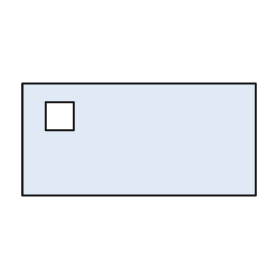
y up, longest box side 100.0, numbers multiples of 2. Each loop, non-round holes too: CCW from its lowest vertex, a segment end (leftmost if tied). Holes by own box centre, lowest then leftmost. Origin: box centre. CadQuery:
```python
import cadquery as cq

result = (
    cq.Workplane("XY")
    .moveTo(-50.0, -24.0)
    .lineTo(50.0, -24.0)
    .lineTo(50.0, 24.0)
    .lineTo(-50.0, 24.0)
    .close()
    .moveTo(-40.0, 4.0)
    .lineTo(-28.0, 4.0)
    .lineTo(-28.0, 16.0)
    .lineTo(-40.0, 16.0)
    .close()
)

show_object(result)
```